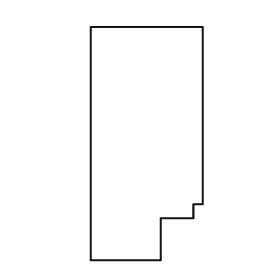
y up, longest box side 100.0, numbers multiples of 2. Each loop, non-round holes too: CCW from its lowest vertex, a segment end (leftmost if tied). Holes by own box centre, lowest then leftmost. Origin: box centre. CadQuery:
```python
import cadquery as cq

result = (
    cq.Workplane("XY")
    .moveTo(-24.0, -50.0)
    .lineTo(6.0, -50.0)
    .lineTo(6.0, -32.0)
    .lineTo(20.0, -32.0)
    .lineTo(20.0, -26.0)
    .lineTo(24.0, -26.0)
    .lineTo(24.0, 50.0)
    .lineTo(-24.0, 50.0)
    .close()
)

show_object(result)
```